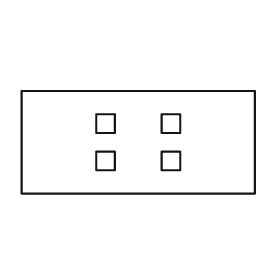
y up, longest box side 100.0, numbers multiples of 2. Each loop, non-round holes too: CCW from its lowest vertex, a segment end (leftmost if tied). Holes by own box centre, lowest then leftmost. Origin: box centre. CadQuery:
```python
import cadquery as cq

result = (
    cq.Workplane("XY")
    .moveTo(-50.0, -22.0)
    .lineTo(50.0, -22.0)
    .lineTo(50.0, 22.0)
    .lineTo(-50.0, 22.0)
    .close()
    .moveTo(-18.0, -12.0)
    .lineTo(-10.0, -12.0)
    .lineTo(-10.0, -4.0)
    .lineTo(-18.0, -4.0)
    .close()
    .moveTo(10.0, -12.0)
    .lineTo(18.0, -12.0)
    .lineTo(18.0, -4.0)
    .lineTo(10.0, -4.0)
    .close()
    .moveTo(-18.0, 4.0)
    .lineTo(-10.0, 4.0)
    .lineTo(-10.0, 12.0)
    .lineTo(-18.0, 12.0)
    .close()
    .moveTo(10.0, 4.0)
    .lineTo(18.0, 4.0)
    .lineTo(18.0, 12.0)
    .lineTo(10.0, 12.0)
    .close()
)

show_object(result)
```